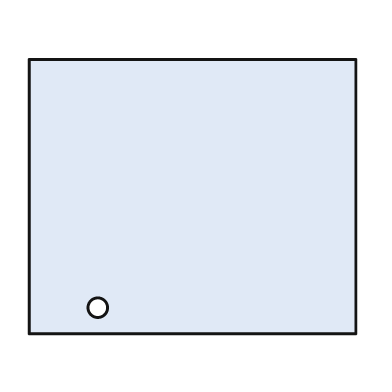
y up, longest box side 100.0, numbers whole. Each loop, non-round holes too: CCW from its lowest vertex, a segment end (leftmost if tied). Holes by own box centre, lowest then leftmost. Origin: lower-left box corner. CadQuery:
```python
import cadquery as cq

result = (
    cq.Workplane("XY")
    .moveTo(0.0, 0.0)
    .lineTo(100.0, 0.0)
    .lineTo(100.0, 84.0)
    .lineTo(0.0, 84.0)
    .close()
    .moveTo(21.0, 8.0)
    .circle(3.0)
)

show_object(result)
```